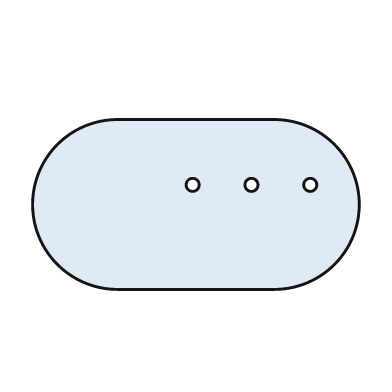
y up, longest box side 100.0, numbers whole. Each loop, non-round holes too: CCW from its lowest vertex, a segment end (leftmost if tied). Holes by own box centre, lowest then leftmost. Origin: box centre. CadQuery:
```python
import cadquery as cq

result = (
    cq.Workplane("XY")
    .moveTo(-24.0, -26.0)
    .lineTo(24.0, -26.0)
    .threePointArc((50.0, 0.0), (24.0, 26.0))
    .lineTo(-24.0, 26.0)
    .threePointArc((-50.0, 0.0), (-24.0, -26.0))
    .close()
    .moveTo(-1.0, 6.0)
    .circle(2.0)
    .moveTo(17.0, 6.0)
    .circle(2.0)
    .moveTo(35.0, 6.0)
    .circle(2.0)
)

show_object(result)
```